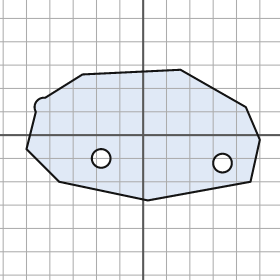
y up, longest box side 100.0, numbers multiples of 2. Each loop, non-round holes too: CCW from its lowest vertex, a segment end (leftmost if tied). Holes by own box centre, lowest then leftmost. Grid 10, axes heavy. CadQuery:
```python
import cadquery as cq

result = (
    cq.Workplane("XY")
    .moveTo(2.0, -28.0)
    .lineTo(46.0, -20.0)
    .lineTo(50.0, -2.0)
    .lineTo(44.0, 12.0)
    .lineTo(16.0, 28.0)
    .lineTo(-26.0, 26.0)
    .lineTo(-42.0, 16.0)
    .threePointArc((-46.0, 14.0), (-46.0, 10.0))
    .lineTo(-50.0, -6.0)
    .lineTo(-36.0, -20.0)
    .close()
    .moveTo(34.0, -12.0)
    .circle(4.0)
    .moveTo(-18.0, -10.0)
    .circle(4.0)
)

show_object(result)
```